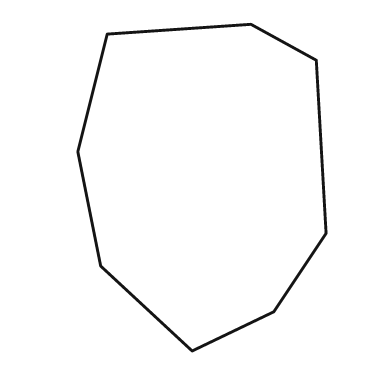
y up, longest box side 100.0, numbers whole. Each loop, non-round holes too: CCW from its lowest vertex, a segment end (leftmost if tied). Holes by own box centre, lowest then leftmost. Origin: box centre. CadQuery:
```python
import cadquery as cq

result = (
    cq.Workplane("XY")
    .moveTo(-3.0, -50.0)
    .lineTo(22.0, -38.0)
    .lineTo(38.0, -14.0)
    .lineTo(35.0, 39.0)
    .lineTo(15.0, 50.0)
    .lineTo(-29.0, 47.0)
    .lineTo(-38.0, 11.0)
    .lineTo(-31.0, -24.0)
    .close()
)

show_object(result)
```